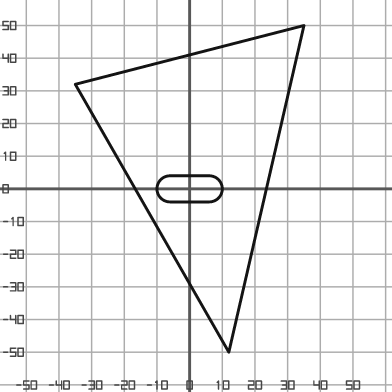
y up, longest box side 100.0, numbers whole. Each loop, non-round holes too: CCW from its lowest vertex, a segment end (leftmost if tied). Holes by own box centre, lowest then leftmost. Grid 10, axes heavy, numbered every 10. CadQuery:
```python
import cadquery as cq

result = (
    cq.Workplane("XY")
    .moveTo(12.0, -50.0)
    .lineTo(35.0, 50.0)
    .lineTo(-35.0, 32.0)
    .close()
    .moveTo(-6.0, -4.0)
    .lineTo(6.0, -4.0)
    .threePointArc((10.0, 0.0), (6.0, 4.0))
    .lineTo(-6.0, 4.0)
    .threePointArc((-10.0, 0.0), (-6.0, -4.0))
    .close()
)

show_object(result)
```